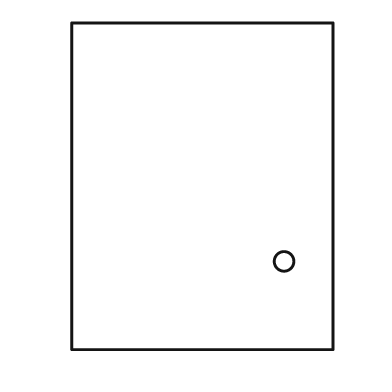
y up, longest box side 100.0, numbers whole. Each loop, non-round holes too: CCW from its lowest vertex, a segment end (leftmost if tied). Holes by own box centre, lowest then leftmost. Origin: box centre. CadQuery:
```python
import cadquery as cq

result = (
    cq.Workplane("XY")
    .moveTo(-40.0, -50.0)
    .lineTo(40.0, -50.0)
    .lineTo(40.0, 50.0)
    .lineTo(-40.0, 50.0)
    .close()
    .moveTo(25.0, -23.0)
    .circle(3.0)
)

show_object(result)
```